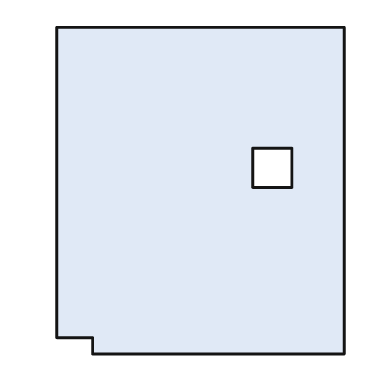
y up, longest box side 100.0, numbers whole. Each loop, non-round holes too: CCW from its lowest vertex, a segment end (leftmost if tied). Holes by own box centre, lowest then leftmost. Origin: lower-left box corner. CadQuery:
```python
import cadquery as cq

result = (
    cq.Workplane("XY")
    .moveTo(11.0, 0.0)
    .lineTo(88.0, 0.0)
    .lineTo(88.0, 100.0)
    .lineTo(0.0, 100.0)
    .lineTo(0.0, 5.0)
    .lineTo(11.0, 5.0)
    .close()
    .moveTo(60.0, 51.0)
    .lineTo(72.0, 51.0)
    .lineTo(72.0, 63.0)
    .lineTo(60.0, 63.0)
    .close()
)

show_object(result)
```